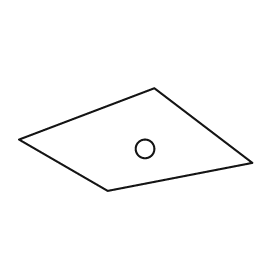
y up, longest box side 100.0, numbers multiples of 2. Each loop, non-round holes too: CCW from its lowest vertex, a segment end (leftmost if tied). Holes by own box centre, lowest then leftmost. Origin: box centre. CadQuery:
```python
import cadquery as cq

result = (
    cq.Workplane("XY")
    .moveTo(-12.0, -22.0)
    .lineTo(50.0, -10.0)
    .lineTo(8.0, 22.0)
    .lineTo(-50.0, 0.0)
    .close()
    .moveTo(4.0, -4.0)
    .circle(4.0)
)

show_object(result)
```